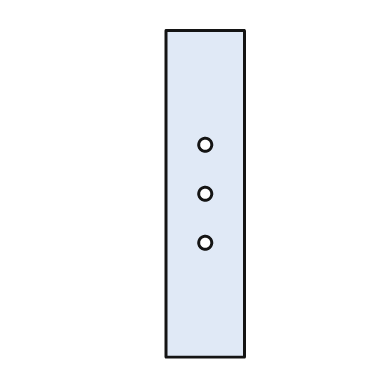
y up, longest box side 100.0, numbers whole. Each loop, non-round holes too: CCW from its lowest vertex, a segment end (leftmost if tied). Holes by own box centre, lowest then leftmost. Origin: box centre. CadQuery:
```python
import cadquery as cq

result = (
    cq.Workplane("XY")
    .moveTo(-12.0, -50.0)
    .lineTo(12.0, -50.0)
    .lineTo(12.0, 50.0)
    .lineTo(-12.0, 50.0)
    .close()
    .moveTo(0.0, -15.0)
    .circle(2.0)
    .moveTo(0.0, 0.0)
    .circle(2.0)
    .moveTo(0.0, 15.0)
    .circle(2.0)
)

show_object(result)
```